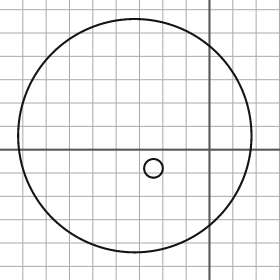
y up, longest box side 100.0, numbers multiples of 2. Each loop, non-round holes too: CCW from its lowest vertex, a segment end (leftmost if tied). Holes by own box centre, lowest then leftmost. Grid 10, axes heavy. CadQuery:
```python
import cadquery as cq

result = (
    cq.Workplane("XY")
    .moveTo(-32.0, 6.0)
    .circle(50.0)
    .moveTo(-24.0, -8.0)
    .circle(4.0)
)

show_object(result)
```